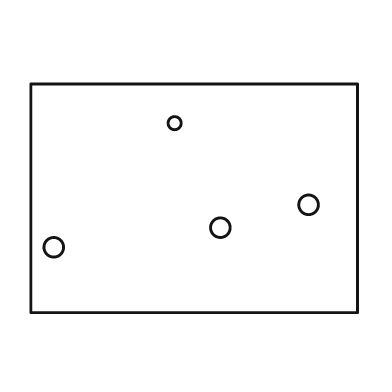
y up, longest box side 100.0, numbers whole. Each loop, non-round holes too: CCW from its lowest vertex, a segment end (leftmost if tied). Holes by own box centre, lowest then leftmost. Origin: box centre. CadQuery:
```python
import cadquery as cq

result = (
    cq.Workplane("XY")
    .moveTo(-50.0, -35.0)
    .lineTo(50.0, -35.0)
    .lineTo(50.0, 35.0)
    .lineTo(-50.0, 35.0)
    .close()
    .moveTo(-43.0, -15.0)
    .circle(3.0)
    .moveTo(8.0, -9.0)
    .circle(3.0)
    .moveTo(35.0, -2.0)
    .circle(3.0)
    .moveTo(-6.0, 23.0)
    .circle(2.0)
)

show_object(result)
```